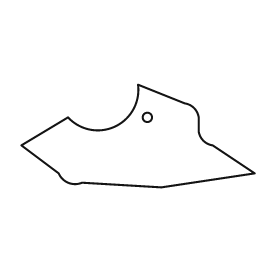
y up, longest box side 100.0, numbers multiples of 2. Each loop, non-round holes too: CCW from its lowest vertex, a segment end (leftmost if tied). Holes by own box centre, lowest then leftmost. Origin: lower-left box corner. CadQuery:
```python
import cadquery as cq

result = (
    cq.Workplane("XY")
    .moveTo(60.0, 0.0)
    .lineTo(100.0, 6.0)
    .lineTo(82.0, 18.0)
    .threePointArc((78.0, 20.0), (76.0, 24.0))
    .lineTo(76.0, 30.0)
    .threePointArc((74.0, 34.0), (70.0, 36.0))
    .lineTo(50.0, 44.0)
    .threePointArc((40.0, 26.0), (20.0, 30.0))
    .lineTo(0.0, 18.0)
    .lineTo(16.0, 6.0)
    .threePointArc((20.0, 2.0), (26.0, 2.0))
    .close()
    .moveTo(54.0, 30.0)
    .circle(2.0)
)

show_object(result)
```